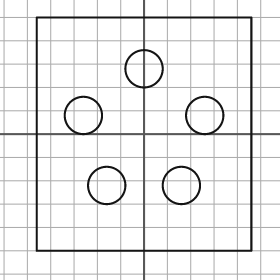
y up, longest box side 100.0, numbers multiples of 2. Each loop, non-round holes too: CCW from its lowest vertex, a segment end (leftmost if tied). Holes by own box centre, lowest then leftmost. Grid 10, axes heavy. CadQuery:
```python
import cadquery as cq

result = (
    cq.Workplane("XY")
    .moveTo(-46.0, -50.0)
    .lineTo(46.0, -50.0)
    .lineTo(46.0, 50.0)
    .lineTo(-46.0, 50.0)
    .close()
    .moveTo(-16.0, -22.0)
    .circle(8.0)
    .moveTo(16.0, -22.0)
    .circle(8.0)
    .moveTo(-26.0, 8.0)
    .circle(8.0)
    .moveTo(26.0, 8.0)
    .circle(8.0)
    .moveTo(0.0, 28.0)
    .circle(8.0)
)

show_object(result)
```